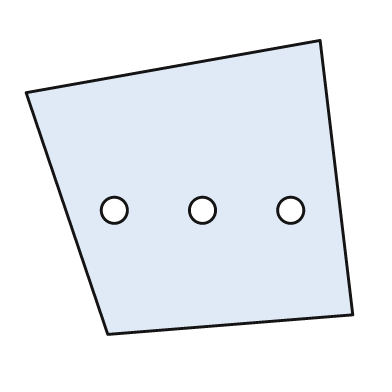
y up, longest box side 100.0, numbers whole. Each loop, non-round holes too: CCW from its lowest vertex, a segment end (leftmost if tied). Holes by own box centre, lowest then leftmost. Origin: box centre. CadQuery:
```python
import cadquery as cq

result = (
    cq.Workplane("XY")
    .moveTo(-25.0, -45.0)
    .lineTo(50.0, -39.0)
    .lineTo(40.0, 45.0)
    .lineTo(-50.0, 29.0)
    .close()
    .moveTo(-23.0, -7.0)
    .circle(4.0)
    .moveTo(4.0, -7.0)
    .circle(4.0)
    .moveTo(31.0, -7.0)
    .circle(4.0)
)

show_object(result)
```